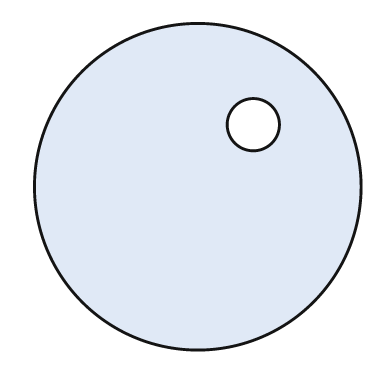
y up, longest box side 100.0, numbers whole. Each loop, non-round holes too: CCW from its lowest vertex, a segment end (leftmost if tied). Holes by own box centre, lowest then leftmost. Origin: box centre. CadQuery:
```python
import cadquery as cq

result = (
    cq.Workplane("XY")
    .moveTo(0.0, 0.0)
    .circle(50.0)
    .moveTo(17.0, 19.0)
    .circle(8.0)
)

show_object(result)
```